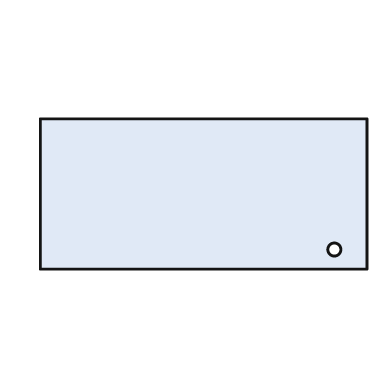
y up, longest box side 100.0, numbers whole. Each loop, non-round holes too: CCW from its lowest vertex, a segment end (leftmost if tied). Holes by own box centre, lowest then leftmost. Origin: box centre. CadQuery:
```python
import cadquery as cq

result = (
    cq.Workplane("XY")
    .moveTo(-50.0, -23.0)
    .lineTo(50.0, -23.0)
    .lineTo(50.0, 23.0)
    .lineTo(-50.0, 23.0)
    .close()
    .moveTo(40.0, -17.0)
    .circle(2.0)
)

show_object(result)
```